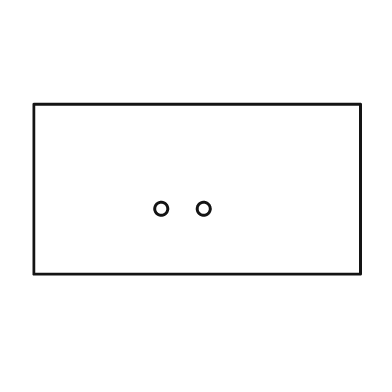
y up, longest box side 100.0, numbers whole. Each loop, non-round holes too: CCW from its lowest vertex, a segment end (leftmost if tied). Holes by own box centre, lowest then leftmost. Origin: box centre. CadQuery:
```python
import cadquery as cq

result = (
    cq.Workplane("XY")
    .moveTo(-50.0, -26.0)
    .lineTo(50.0, -26.0)
    .lineTo(50.0, 26.0)
    .lineTo(-50.0, 26.0)
    .close()
    .moveTo(-11.0, -6.0)
    .circle(2.0)
    .moveTo(2.0, -6.0)
    .circle(2.0)
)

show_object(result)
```